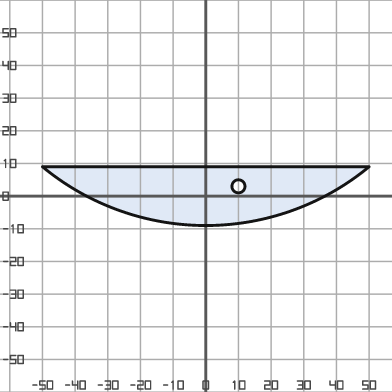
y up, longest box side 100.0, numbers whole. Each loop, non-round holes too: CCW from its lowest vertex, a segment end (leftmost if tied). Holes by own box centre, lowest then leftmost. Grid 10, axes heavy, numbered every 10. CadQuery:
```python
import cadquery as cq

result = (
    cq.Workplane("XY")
    .moveTo(-50.0, 9.0)
    .threePointArc((0.0, -9.0), (50.0, 9.0))
    .close()
    .moveTo(10.0, 3.0)
    .circle(2.0)
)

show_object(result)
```